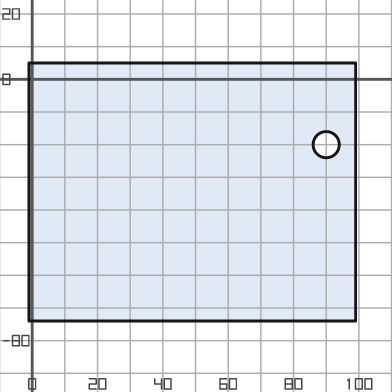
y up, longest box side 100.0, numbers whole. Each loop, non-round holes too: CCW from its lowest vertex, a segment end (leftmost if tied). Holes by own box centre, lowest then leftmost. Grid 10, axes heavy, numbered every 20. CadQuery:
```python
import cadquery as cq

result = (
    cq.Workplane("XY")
    .moveTo(-1.0, -74.0)
    .lineTo(99.0, -74.0)
    .lineTo(99.0, 5.0)
    .lineTo(-1.0, 5.0)
    .close()
    .moveTo(90.0, -20.0)
    .circle(4.0)
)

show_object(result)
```